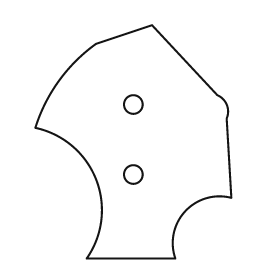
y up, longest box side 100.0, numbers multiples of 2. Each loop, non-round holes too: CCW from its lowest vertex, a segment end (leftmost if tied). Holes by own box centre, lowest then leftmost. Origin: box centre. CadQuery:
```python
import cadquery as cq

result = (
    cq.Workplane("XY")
    .moveTo(-20.0, -50.0)
    .lineTo(18.0, -50.0)
    .threePointArc((22.0, -30.0), (42.0, -24.0))
    .lineTo(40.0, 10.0)
    .threePointArc((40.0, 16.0), (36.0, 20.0))
    .lineTo(8.0, 50.0)
    .lineTo(-16.0, 42.0)
    .threePointArc((-32.0, 26.0), (-42.0, 6.0))
    .threePointArc((-16.0, -16.0), (-20.0, -50.0))
    .close()
    .moveTo(0.0, -14.0)
    .circle(4.0)
    .moveTo(0.0, 16.0)
    .circle(4.0)
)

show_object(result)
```